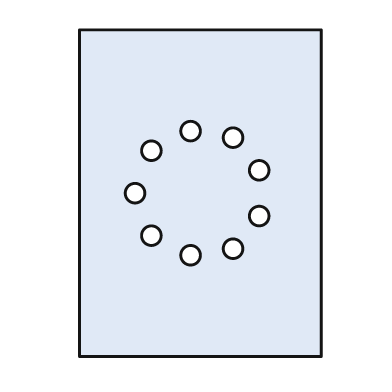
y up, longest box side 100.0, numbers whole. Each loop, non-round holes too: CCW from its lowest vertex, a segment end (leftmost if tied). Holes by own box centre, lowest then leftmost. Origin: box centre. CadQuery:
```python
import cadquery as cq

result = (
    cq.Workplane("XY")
    .moveTo(-37.0, -50.0)
    .lineTo(37.0, -50.0)
    .lineTo(37.0, 50.0)
    .lineTo(-37.0, 50.0)
    .close()
    .moveTo(-3.0, -19.0)
    .circle(3.0)
    .moveTo(10.0, -17.0)
    .circle(3.0)
    .moveTo(-15.0, -13.0)
    .circle(3.0)
    .moveTo(18.0, -7.0)
    .circle(3.0)
    .moveTo(-20.0, 0.0)
    .circle(3.0)
    .moveTo(18.0, 7.0)
    .circle(3.0)
    .moveTo(-15.0, 13.0)
    .circle(3.0)
    .moveTo(10.0, 17.0)
    .circle(3.0)
    .moveTo(-3.0, 19.0)
    .circle(3.0)
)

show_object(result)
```